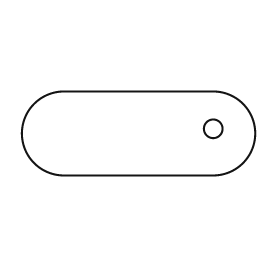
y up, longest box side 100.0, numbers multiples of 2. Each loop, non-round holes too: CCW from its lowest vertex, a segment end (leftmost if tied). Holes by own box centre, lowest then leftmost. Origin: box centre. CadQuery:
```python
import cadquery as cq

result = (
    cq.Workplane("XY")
    .moveTo(-32.0, -18.0)
    .lineTo(32.0, -18.0)
    .threePointArc((50.0, 0.0), (32.0, 18.0))
    .lineTo(-32.0, 18.0)
    .threePointArc((-50.0, 0.0), (-32.0, -18.0))
    .close()
    .moveTo(32.0, 2.0)
    .circle(4.0)
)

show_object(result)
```